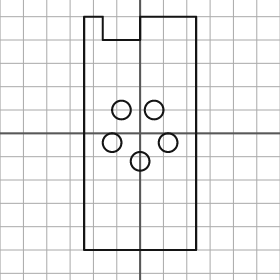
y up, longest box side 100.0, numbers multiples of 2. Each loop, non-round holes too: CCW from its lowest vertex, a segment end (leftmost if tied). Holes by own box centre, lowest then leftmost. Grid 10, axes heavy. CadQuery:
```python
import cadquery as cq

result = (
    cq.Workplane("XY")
    .moveTo(-24.0, -50.0)
    .lineTo(24.0, -50.0)
    .lineTo(24.0, 50.0)
    .lineTo(0.0, 50.0)
    .lineTo(0.0, 40.0)
    .lineTo(-16.0, 40.0)
    .lineTo(-16.0, 50.0)
    .lineTo(-24.0, 50.0)
    .close()
    .moveTo(0.0, -12.0)
    .circle(4.0)
    .moveTo(-12.0, -4.0)
    .circle(4.0)
    .moveTo(12.0, -4.0)
    .circle(4.0)
    .moveTo(-8.0, 10.0)
    .circle(4.0)
    .moveTo(6.0, 10.0)
    .circle(4.0)
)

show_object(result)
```